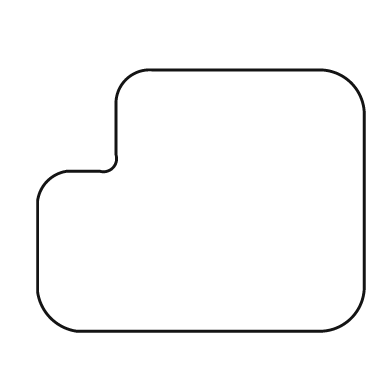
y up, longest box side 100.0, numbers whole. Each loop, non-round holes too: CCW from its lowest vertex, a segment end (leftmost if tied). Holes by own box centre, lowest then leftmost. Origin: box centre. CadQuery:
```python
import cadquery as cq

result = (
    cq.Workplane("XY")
    .moveTo(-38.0, -40.0)
    .lineTo(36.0, -40.0)
    .threePointArc((46.0, -36.0), (50.0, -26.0))
    .lineTo(50.0, 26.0)
    .threePointArc((46.0, 36.0), (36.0, 40.0))
    .lineTo(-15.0, 40.0)
    .threePointArc((-23.0, 37.0), (-26.0, 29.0))
    .lineTo(-26.0, 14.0)
    .threePointArc((-27.0, 10.0), (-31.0, 9.0))
    .lineTo(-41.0, 9.0)
    .threePointArc((-47.0, 6.0), (-50.0, 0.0))
    .lineTo(-50.0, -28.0)
    .threePointArc((-46.0, -36.0), (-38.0, -40.0))
    .close()
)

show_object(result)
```